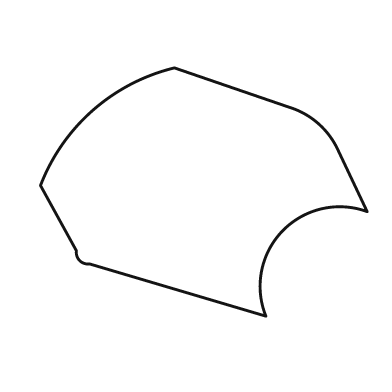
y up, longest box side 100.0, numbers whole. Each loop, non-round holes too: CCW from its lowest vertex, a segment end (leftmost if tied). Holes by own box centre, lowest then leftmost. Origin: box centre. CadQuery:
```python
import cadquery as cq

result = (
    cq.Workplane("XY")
    .moveTo(19.0, -38.0)
    .threePointArc((24.0, -12.0), (50.0, -6.0))
    .lineTo(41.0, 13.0)
    .threePointArc((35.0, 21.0), (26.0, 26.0))
    .lineTo(-9.0, 38.0)
    .threePointArc((-34.0, 25.0), (-50.0, 2.0))
    .lineTo(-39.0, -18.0)
    .threePointArc((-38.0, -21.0), (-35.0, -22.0))
    .close()
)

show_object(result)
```